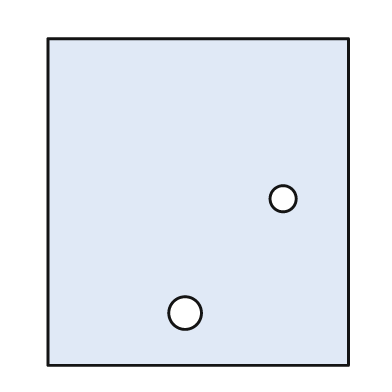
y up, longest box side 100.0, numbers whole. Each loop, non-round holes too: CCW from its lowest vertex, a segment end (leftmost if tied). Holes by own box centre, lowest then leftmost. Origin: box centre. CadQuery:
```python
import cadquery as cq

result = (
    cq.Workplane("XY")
    .moveTo(-46.0, -50.0)
    .lineTo(46.0, -50.0)
    .lineTo(46.0, 50.0)
    .lineTo(-46.0, 50.0)
    .close()
    .moveTo(-4.0, -34.0)
    .circle(5.0)
    .moveTo(26.0, 1.0)
    .circle(4.0)
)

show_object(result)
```